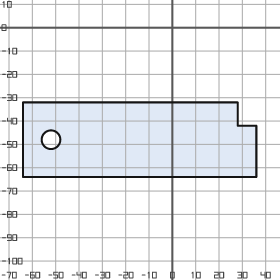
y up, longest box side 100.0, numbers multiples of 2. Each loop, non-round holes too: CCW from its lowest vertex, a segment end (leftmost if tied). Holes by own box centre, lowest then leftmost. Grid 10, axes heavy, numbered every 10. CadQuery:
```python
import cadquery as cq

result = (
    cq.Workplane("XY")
    .moveTo(-64.0, -64.0)
    .lineTo(36.0, -64.0)
    .lineTo(36.0, -42.0)
    .lineTo(28.0, -42.0)
    .lineTo(28.0, -32.0)
    .lineTo(-64.0, -32.0)
    .close()
    .moveTo(-52.0, -48.0)
    .circle(4.0)
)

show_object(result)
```